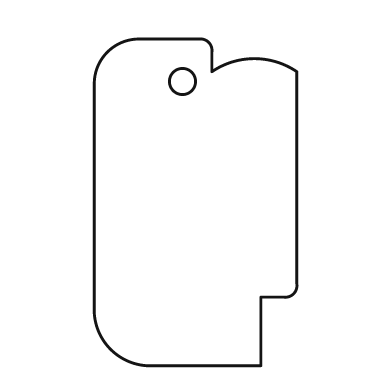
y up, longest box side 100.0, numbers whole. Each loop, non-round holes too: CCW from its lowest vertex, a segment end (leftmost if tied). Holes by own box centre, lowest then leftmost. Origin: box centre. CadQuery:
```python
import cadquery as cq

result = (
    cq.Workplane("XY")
    .moveTo(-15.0, -50.0)
    .lineTo(20.0, -50.0)
    .lineTo(20.0, -29.0)
    .lineTo(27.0, -29.0)
    .threePointArc((30.0, -28.0), (31.0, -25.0))
    .lineTo(31.0, 40.0)
    .threePointArc((18.0, 44.0), (5.0, 40.0))
    .lineTo(5.0, 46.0)
    .threePointArc((4.0, 49.0), (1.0, 50.0))
    .lineTo(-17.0, 50.0)
    .threePointArc((-27.0, 46.0), (-31.0, 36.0))
    .lineTo(-31.0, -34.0)
    .threePointArc((-26.0, -45.0), (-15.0, -50.0))
    .close()
    .moveTo(-4.0, 37.0)
    .circle(4.0)
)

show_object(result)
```